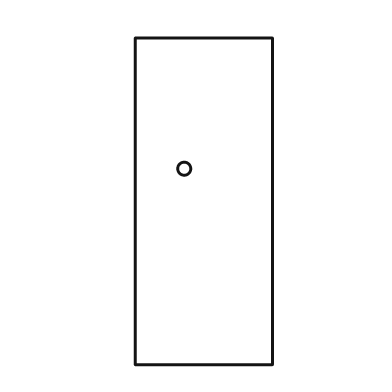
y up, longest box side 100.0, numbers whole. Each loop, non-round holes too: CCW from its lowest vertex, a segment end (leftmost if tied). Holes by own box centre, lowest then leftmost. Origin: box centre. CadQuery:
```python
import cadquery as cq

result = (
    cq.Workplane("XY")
    .moveTo(-21.0, -50.0)
    .lineTo(21.0, -50.0)
    .lineTo(21.0, 50.0)
    .lineTo(-21.0, 50.0)
    .close()
    .moveTo(-6.0, 10.0)
    .circle(2.0)
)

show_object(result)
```